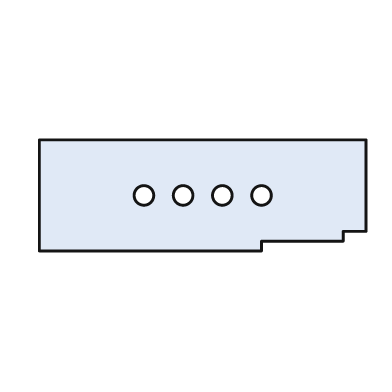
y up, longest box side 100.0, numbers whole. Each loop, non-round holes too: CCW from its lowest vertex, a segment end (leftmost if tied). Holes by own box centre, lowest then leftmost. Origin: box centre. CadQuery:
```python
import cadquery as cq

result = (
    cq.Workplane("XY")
    .moveTo(-50.0, -17.0)
    .lineTo(18.0, -17.0)
    .lineTo(18.0, -14.0)
    .lineTo(43.0, -14.0)
    .lineTo(43.0, -11.0)
    .lineTo(50.0, -11.0)
    .lineTo(50.0, 17.0)
    .lineTo(-50.0, 17.0)
    .close()
    .moveTo(-18.0, 0.0)
    .circle(3.0)
    .moveTo(-6.0, 0.0)
    .circle(3.0)
    .moveTo(6.0, 0.0)
    .circle(3.0)
    .moveTo(18.0, 0.0)
    .circle(3.0)
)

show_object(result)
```